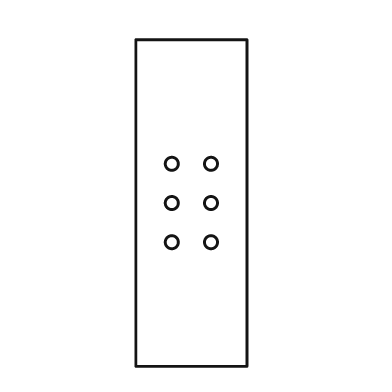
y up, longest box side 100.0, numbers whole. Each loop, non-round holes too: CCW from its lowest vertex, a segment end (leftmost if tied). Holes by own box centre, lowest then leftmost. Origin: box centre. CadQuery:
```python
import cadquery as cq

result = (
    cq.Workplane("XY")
    .moveTo(-17.0, -50.0)
    .lineTo(17.0, -50.0)
    .lineTo(17.0, 50.0)
    .lineTo(-17.0, 50.0)
    .close()
    .moveTo(-6.0, -12.0)
    .circle(2.0)
    .moveTo(6.0, -12.0)
    .circle(2.0)
    .moveTo(-6.0, 0.0)
    .circle(2.0)
    .moveTo(6.0, 0.0)
    .circle(2.0)
    .moveTo(-6.0, 12.0)
    .circle(2.0)
    .moveTo(6.0, 12.0)
    .circle(2.0)
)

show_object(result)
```